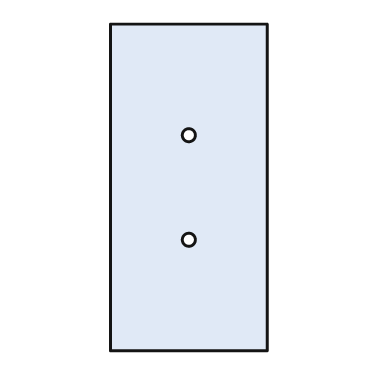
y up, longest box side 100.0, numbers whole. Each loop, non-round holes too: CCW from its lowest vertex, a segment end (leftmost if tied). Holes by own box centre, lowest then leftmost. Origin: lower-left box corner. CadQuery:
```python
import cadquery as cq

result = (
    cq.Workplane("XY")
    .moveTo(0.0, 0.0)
    .lineTo(48.0, 0.0)
    .lineTo(48.0, 100.0)
    .lineTo(0.0, 100.0)
    .close()
    .moveTo(24.0, 34.0)
    .circle(2.0)
    .moveTo(24.0, 66.0)
    .circle(2.0)
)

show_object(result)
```